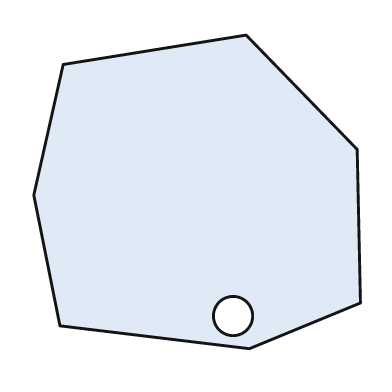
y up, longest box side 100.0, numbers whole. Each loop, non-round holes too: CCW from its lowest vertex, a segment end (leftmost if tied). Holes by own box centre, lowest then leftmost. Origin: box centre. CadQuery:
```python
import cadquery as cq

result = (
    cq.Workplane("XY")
    .moveTo(16.0, -48.0)
    .lineTo(50.0, -34.0)
    .lineTo(49.0, 13.0)
    .lineTo(15.0, 48.0)
    .lineTo(-41.0, 39.0)
    .lineTo(-50.0, -1.0)
    .lineTo(-42.0, -41.0)
    .close()
    .moveTo(11.0, -38.0)
    .circle(6.0)
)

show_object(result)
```